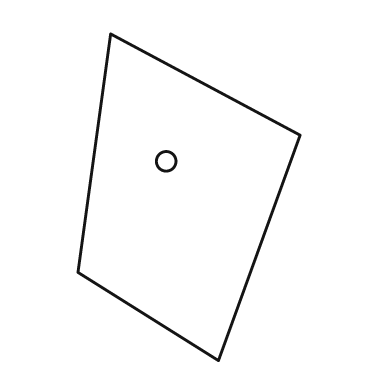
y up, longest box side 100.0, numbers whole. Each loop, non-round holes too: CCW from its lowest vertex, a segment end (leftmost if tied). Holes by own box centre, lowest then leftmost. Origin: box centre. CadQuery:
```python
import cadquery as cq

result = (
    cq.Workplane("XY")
    .moveTo(9.0, -50.0)
    .lineTo(34.0, 19.0)
    .lineTo(-24.0, 50.0)
    .lineTo(-34.0, -23.0)
    .close()
    .moveTo(-7.0, 11.0)
    .circle(3.0)
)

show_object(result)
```